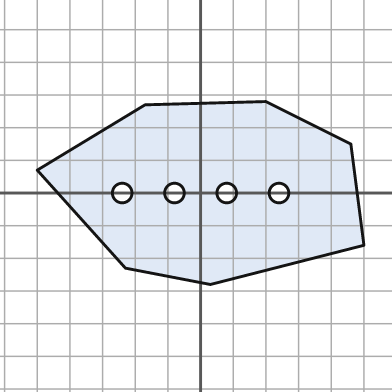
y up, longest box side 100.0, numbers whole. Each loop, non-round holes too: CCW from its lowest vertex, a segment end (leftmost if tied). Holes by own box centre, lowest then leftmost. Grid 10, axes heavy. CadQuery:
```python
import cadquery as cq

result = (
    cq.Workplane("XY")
    .moveTo(3.0, -28.0)
    .lineTo(50.0, -16.0)
    .lineTo(46.0, 15.0)
    .lineTo(20.0, 28.0)
    .lineTo(-17.0, 27.0)
    .lineTo(-50.0, 7.0)
    .lineTo(-23.0, -23.0)
    .close()
    .moveTo(-24.0, 0.0)
    .circle(3.0)
    .moveTo(-8.0, 0.0)
    .circle(3.0)
    .moveTo(8.0, 0.0)
    .circle(3.0)
    .moveTo(24.0, 0.0)
    .circle(3.0)
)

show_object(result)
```